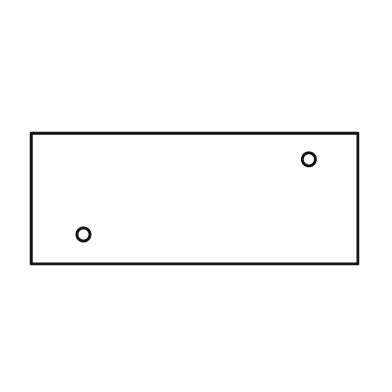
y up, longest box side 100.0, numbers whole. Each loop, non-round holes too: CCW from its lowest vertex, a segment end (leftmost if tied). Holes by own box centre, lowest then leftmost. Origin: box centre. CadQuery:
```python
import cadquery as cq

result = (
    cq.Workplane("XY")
    .moveTo(-50.0, -20.0)
    .lineTo(50.0, -20.0)
    .lineTo(50.0, 20.0)
    .lineTo(-50.0, 20.0)
    .close()
    .moveTo(-34.0, -11.0)
    .circle(2.0)
    .moveTo(35.0, 12.0)
    .circle(2.0)
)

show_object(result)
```